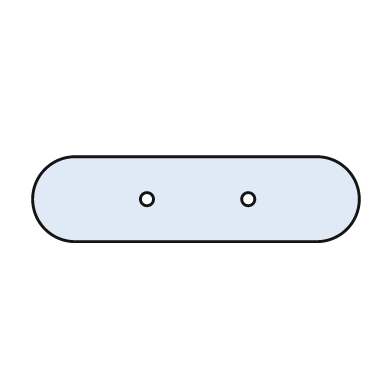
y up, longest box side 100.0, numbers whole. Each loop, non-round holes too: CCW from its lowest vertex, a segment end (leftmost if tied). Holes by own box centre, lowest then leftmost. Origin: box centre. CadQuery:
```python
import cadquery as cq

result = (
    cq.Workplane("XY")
    .moveTo(-37.0, -13.0)
    .lineTo(37.0, -13.0)
    .threePointArc((50.0, 0.0), (37.0, 13.0))
    .lineTo(-37.0, 13.0)
    .threePointArc((-50.0, 0.0), (-37.0, -13.0))
    .close()
    .moveTo(-15.0, 0.0)
    .circle(2.0)
    .moveTo(16.0, 0.0)
    .circle(2.0)
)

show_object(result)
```